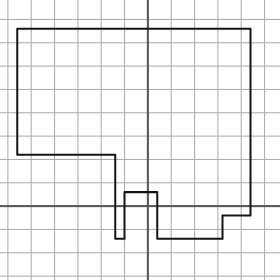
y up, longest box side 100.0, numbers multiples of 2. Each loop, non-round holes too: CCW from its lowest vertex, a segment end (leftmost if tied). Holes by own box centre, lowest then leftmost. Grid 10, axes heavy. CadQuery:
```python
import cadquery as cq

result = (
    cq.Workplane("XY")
    .moveTo(-14.0, -14.0)
    .lineTo(-10.0, -14.0)
    .lineTo(-10.0, 6.0)
    .lineTo(4.0, 6.0)
    .lineTo(4.0, -14.0)
    .lineTo(32.0, -14.0)
    .lineTo(32.0, -4.0)
    .lineTo(44.0, -4.0)
    .lineTo(44.0, 76.0)
    .lineTo(-56.0, 76.0)
    .lineTo(-56.0, 22.0)
    .lineTo(-14.0, 22.0)
    .close()
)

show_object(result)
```